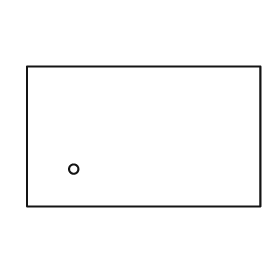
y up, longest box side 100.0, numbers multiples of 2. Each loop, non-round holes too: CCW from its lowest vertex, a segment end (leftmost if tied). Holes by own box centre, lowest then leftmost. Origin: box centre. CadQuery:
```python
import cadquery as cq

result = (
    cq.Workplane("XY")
    .moveTo(-50.0, -30.0)
    .lineTo(50.0, -30.0)
    .lineTo(50.0, 30.0)
    .lineTo(-50.0, 30.0)
    .close()
    .moveTo(-30.0, -14.0)
    .circle(2.0)
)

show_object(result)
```